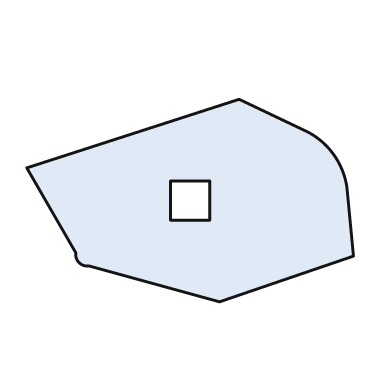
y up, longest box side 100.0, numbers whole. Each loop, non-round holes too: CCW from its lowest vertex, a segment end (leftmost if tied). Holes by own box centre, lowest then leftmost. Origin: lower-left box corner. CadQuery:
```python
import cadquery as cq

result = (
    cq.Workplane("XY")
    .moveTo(59.0, 0.0)
    .lineTo(100.0, 14.0)
    .lineTo(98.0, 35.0)
    .threePointArc((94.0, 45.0), (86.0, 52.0))
    .lineTo(65.0, 62.0)
    .lineTo(0.0, 41.0)
    .lineTo(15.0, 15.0)
    .threePointArc((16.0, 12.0), (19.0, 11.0))
    .close()
    .moveTo(44.0, 25.0)
    .lineTo(56.0, 25.0)
    .lineTo(56.0, 37.0)
    .lineTo(44.0, 37.0)
    .close()
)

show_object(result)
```